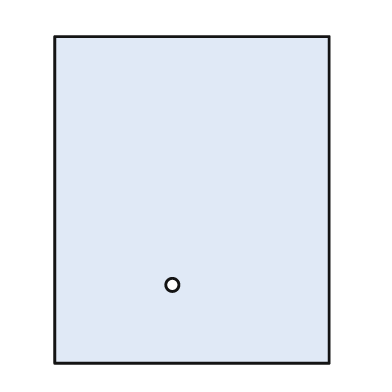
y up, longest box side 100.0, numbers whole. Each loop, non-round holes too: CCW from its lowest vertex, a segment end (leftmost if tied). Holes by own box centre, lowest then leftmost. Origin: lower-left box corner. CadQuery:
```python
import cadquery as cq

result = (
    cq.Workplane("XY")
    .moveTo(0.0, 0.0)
    .lineTo(84.0, 0.0)
    .lineTo(84.0, 100.0)
    .lineTo(0.0, 100.0)
    .close()
    .moveTo(36.0, 24.0)
    .circle(2.0)
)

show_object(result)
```